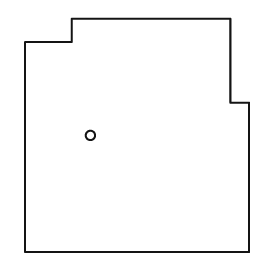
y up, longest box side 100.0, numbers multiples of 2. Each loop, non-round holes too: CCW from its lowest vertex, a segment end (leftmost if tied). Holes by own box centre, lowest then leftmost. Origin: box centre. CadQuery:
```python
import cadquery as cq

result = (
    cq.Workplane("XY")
    .moveTo(-48.0, -50.0)
    .lineTo(48.0, -50.0)
    .lineTo(48.0, 14.0)
    .lineTo(40.0, 14.0)
    .lineTo(40.0, 50.0)
    .lineTo(-28.0, 50.0)
    .lineTo(-28.0, 40.0)
    .lineTo(-48.0, 40.0)
    .close()
    .moveTo(-20.0, 0.0)
    .circle(2.0)
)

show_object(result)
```